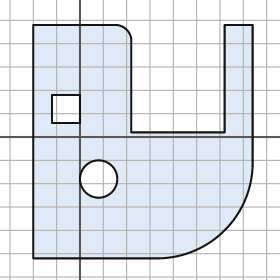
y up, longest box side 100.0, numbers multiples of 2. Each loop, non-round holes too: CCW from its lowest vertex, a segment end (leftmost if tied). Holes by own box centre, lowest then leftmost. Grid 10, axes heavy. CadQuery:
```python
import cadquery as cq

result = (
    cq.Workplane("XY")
    .moveTo(-20.0, -52.0)
    .lineTo(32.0, -52.0)
    .threePointArc((62.0, -40.0), (74.0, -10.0))
    .lineTo(74.0, 48.0)
    .lineTo(62.0, 48.0)
    .lineTo(62.0, 2.0)
    .lineTo(22.0, 2.0)
    .lineTo(22.0, 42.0)
    .threePointArc((20.0, 46.0), (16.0, 48.0))
    .lineTo(-20.0, 48.0)
    .close()
    .moveTo(8.0, -18.0)
    .circle(8.0)
    .moveTo(-12.0, 6.0)
    .lineTo(0.0, 6.0)
    .lineTo(0.0, 18.0)
    .lineTo(-12.0, 18.0)
    .close()
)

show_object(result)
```